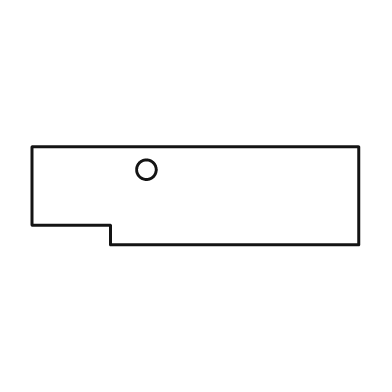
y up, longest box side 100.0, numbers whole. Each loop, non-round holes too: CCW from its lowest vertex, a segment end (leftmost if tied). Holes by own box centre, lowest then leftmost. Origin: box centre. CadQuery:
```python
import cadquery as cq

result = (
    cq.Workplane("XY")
    .moveTo(-26.0, -15.0)
    .lineTo(50.0, -15.0)
    .lineTo(50.0, 15.0)
    .lineTo(-50.0, 15.0)
    .lineTo(-50.0, -9.0)
    .lineTo(-26.0, -9.0)
    .close()
    .moveTo(-15.0, 8.0)
    .circle(3.0)
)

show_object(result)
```